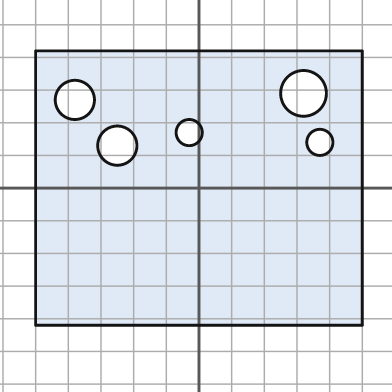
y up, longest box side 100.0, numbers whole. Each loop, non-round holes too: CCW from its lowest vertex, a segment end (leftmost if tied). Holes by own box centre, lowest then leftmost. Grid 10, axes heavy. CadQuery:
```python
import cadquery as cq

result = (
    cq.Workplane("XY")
    .moveTo(-50.0, -42.0)
    .lineTo(50.0, -42.0)
    .lineTo(50.0, 42.0)
    .lineTo(-50.0, 42.0)
    .close()
    .moveTo(-25.0, 13.0)
    .circle(6.0)
    .moveTo(37.0, 14.0)
    .circle(4.0)
    .moveTo(-3.0, 17.0)
    .circle(4.0)
    .moveTo(-38.0, 27.0)
    .circle(6.0)
    .moveTo(32.0, 29.0)
    .circle(7.0)
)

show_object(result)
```